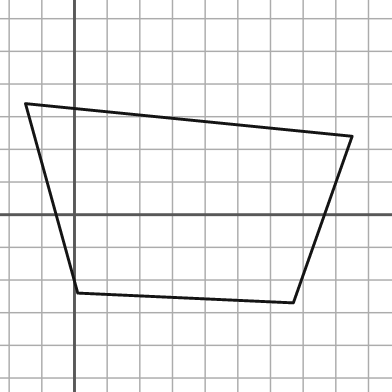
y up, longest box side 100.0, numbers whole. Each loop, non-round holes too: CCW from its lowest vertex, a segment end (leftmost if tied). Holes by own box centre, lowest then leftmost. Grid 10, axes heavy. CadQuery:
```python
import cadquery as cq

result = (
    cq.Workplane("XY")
    .moveTo(67.0, -27.0)
    .lineTo(85.0, 24.0)
    .lineTo(-15.0, 34.0)
    .lineTo(1.0, -24.0)
    .close()
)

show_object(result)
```